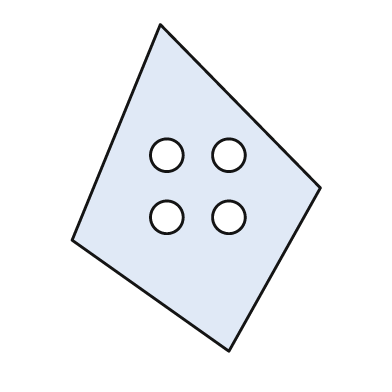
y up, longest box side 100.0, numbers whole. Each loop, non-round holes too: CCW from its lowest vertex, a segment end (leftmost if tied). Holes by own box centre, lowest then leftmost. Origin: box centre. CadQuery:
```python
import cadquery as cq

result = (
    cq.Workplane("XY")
    .moveTo(10.0, -50.0)
    .lineTo(38.0, 0.0)
    .lineTo(-11.0, 50.0)
    .lineTo(-38.0, -16.0)
    .close()
    .moveTo(-9.0, -9.0)
    .circle(5.0)
    .moveTo(10.0, -9.0)
    .circle(5.0)
    .moveTo(-9.0, 10.0)
    .circle(5.0)
    .moveTo(10.0, 10.0)
    .circle(5.0)
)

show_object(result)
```